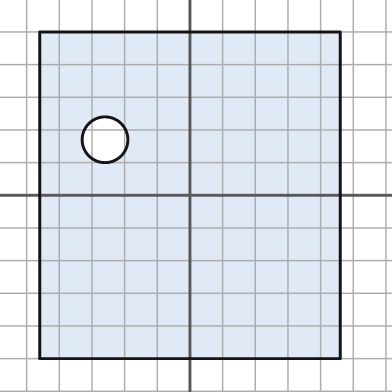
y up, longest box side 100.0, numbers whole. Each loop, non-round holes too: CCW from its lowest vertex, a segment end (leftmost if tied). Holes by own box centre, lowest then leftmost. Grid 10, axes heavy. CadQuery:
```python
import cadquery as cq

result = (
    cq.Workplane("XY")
    .moveTo(-46.0, -50.0)
    .lineTo(46.0, -50.0)
    .lineTo(46.0, 50.0)
    .lineTo(-46.0, 50.0)
    .close()
    .moveTo(-26.0, 17.0)
    .circle(7.0)
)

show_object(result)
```